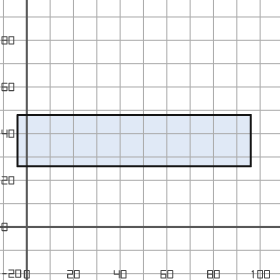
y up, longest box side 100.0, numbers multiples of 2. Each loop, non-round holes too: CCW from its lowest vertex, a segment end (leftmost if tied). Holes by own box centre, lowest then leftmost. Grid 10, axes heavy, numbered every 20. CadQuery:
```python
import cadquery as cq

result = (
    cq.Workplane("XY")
    .moveTo(-4.0, 26.0)
    .lineTo(96.0, 26.0)
    .lineTo(96.0, 48.0)
    .lineTo(-4.0, 48.0)
    .close()
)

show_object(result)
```